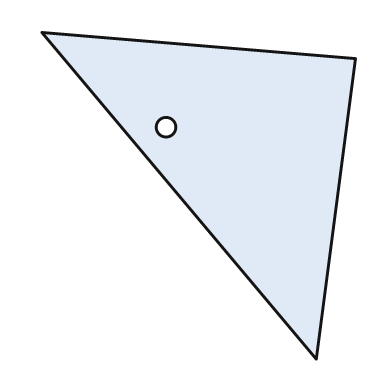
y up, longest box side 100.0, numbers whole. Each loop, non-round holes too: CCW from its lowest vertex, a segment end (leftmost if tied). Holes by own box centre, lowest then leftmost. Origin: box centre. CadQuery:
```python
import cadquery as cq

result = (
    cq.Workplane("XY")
    .moveTo(36.0, -50.0)
    .lineTo(48.0, 42.0)
    .lineTo(-48.0, 50.0)
    .close()
    .moveTo(-10.0, 21.0)
    .circle(3.0)
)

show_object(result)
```